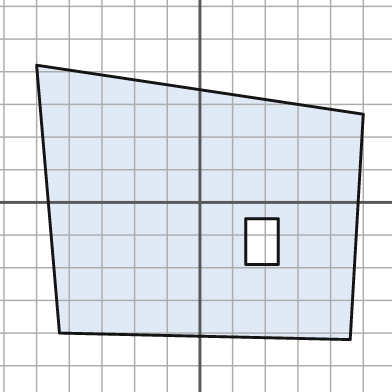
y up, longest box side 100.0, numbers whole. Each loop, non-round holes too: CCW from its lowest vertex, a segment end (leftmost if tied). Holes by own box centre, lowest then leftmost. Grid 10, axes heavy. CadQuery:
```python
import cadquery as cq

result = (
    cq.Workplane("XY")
    .moveTo(46.0, -42.0)
    .lineTo(50.0, 27.0)
    .lineTo(-50.0, 42.0)
    .lineTo(-43.0, -40.0)
    .close()
    .moveTo(14.0, -19.0)
    .lineTo(24.0, -19.0)
    .lineTo(24.0, -5.0)
    .lineTo(14.0, -5.0)
    .close()
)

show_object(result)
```